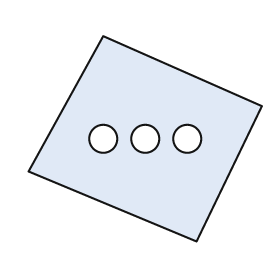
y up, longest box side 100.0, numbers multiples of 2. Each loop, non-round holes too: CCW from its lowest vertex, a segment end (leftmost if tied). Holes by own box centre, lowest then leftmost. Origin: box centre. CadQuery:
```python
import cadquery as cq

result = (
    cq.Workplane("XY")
    .moveTo(22.0, -44.0)
    .lineTo(50.0, 14.0)
    .lineTo(-18.0, 44.0)
    .lineTo(-50.0, -14.0)
    .close()
    .moveTo(-18.0, 0.0)
    .circle(6.0)
    .moveTo(0.0, 0.0)
    .circle(6.0)
    .moveTo(18.0, 0.0)
    .circle(6.0)
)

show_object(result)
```